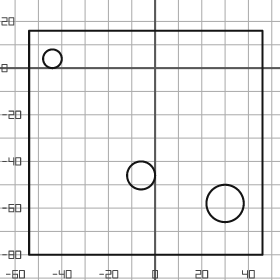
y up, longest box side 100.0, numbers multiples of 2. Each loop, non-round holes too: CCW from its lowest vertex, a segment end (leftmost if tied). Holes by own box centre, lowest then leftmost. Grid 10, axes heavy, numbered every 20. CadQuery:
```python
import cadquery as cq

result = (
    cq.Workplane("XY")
    .moveTo(-54.0, -80.0)
    .lineTo(46.0, -80.0)
    .lineTo(46.0, 16.0)
    .lineTo(-54.0, 16.0)
    .close()
    .moveTo(30.0, -58.0)
    .circle(8.0)
    .moveTo(-6.0, -46.0)
    .circle(6.0)
    .moveTo(-44.0, 4.0)
    .circle(4.0)
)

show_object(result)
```